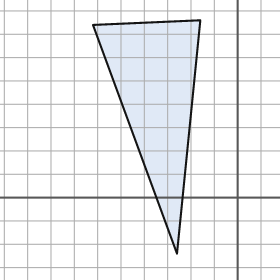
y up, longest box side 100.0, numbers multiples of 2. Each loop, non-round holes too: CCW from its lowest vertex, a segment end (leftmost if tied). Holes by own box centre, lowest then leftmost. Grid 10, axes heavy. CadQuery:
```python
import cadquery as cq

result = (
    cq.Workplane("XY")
    .moveTo(-26.0, -24.0)
    .lineTo(-16.0, 76.0)
    .lineTo(-62.0, 74.0)
    .close()
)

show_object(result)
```